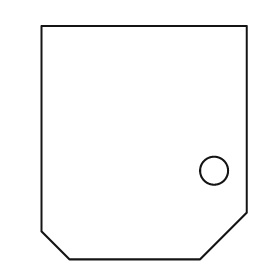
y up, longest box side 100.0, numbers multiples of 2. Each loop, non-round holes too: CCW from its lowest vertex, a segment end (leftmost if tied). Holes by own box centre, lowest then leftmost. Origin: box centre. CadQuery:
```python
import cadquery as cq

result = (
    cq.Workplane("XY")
    .moveTo(-32.0, -50.0)
    .lineTo(24.0, -50.0)
    .lineTo(44.0, -30.0)
    .lineTo(44.0, 50.0)
    .lineTo(-44.0, 50.0)
    .lineTo(-44.0, -38.0)
    .close()
    .moveTo(30.0, -12.0)
    .circle(6.0)
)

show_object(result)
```